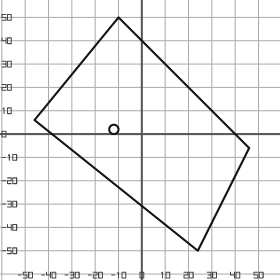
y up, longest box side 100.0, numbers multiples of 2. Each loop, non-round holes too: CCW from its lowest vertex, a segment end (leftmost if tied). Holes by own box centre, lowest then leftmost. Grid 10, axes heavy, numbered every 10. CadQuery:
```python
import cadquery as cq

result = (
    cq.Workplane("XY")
    .moveTo(24.0, -50.0)
    .lineTo(46.0, -6.0)
    .lineTo(-10.0, 50.0)
    .lineTo(-46.0, 6.0)
    .close()
    .moveTo(-12.0, 2.0)
    .circle(2.0)
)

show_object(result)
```